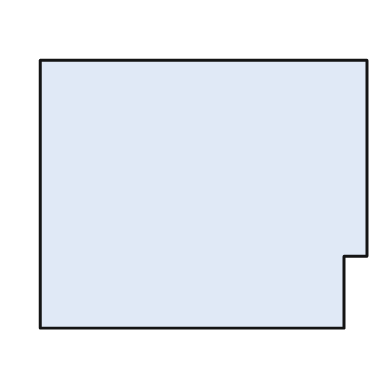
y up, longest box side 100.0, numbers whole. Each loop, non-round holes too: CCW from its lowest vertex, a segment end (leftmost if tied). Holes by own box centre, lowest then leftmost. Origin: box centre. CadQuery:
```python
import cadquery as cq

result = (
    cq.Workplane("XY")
    .moveTo(-50.0, -41.0)
    .lineTo(43.0, -41.0)
    .lineTo(43.0, -19.0)
    .lineTo(50.0, -19.0)
    .lineTo(50.0, 41.0)
    .lineTo(-50.0, 41.0)
    .close()
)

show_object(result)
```